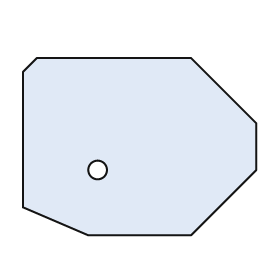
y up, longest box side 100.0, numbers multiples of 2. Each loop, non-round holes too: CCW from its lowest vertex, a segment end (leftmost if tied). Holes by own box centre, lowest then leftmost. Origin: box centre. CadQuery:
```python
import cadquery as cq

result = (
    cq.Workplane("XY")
    .moveTo(-22.0, -38.0)
    .lineTo(22.0, -38.0)
    .lineTo(50.0, -10.0)
    .lineTo(50.0, 10.0)
    .lineTo(22.0, 38.0)
    .lineTo(-44.0, 38.0)
    .lineTo(-50.0, 32.0)
    .lineTo(-50.0, -26.0)
    .close()
    .moveTo(-18.0, -10.0)
    .circle(4.0)
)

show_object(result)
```